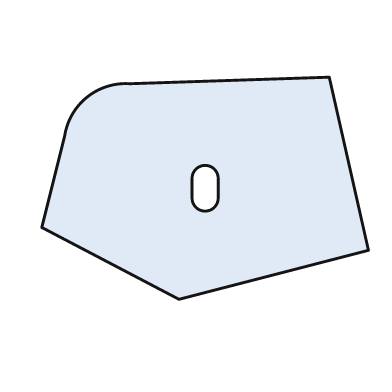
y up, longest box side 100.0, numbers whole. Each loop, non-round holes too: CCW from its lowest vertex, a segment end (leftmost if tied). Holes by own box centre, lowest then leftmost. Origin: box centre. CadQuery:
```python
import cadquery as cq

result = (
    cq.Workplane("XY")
    .moveTo(-8.0, -34.0)
    .lineTo(50.0, -19.0)
    .lineTo(38.0, 34.0)
    .lineTo(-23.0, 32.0)
    .threePointArc((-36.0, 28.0), (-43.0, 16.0))
    .lineTo(-50.0, -12.0)
    .close()
    .moveTo(-4.0, -3.0)
    .threePointArc((0.0, -7.0), (4.0, -3.0))
    .lineTo(4.0, 3.0)
    .threePointArc((0.0, 7.0), (-4.0, 3.0))
    .close()
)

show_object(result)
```